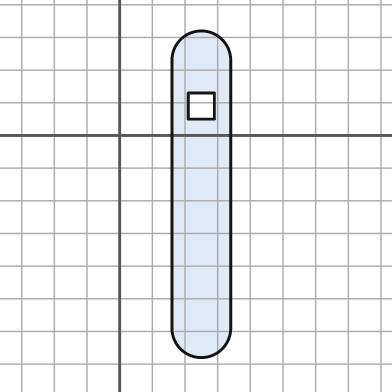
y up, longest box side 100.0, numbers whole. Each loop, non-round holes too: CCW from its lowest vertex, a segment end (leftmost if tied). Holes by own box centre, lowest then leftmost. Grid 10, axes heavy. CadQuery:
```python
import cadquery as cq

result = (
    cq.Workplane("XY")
    .moveTo(16.0, -59.0)
    .threePointArc((25.0, -68.0), (34.0, -59.0))
    .lineTo(34.0, 23.0)
    .threePointArc((25.0, 32.0), (16.0, 23.0))
    .close()
    .moveTo(21.0, 5.0)
    .lineTo(29.0, 5.0)
    .lineTo(29.0, 13.0)
    .lineTo(21.0, 13.0)
    .close()
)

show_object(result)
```